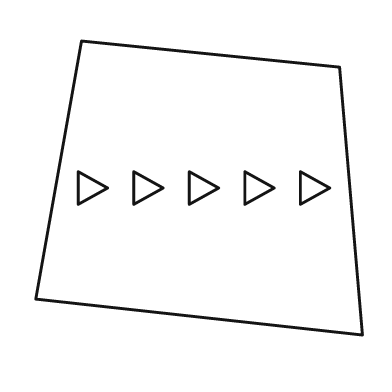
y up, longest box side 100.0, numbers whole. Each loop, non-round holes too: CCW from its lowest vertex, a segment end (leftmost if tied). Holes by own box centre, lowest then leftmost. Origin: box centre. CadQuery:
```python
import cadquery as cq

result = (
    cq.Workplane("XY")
    .moveTo(50.0, -45.0)
    .lineTo(43.0, 37.0)
    .lineTo(-36.0, 45.0)
    .lineTo(-50.0, -34.0)
    .close()
    .moveTo(-37.0, -5.0)
    .lineTo(-28.0, 0.0)
    .lineTo(-37.0, 5.0)
    .close()
    .moveTo(-20.0, -5.0)
    .lineTo(-11.0, 0.0)
    .lineTo(-20.0, 5.0)
    .close()
    .moveTo(-3.0, -5.0)
    .lineTo(6.0, 0.0)
    .lineTo(-3.0, 5.0)
    .close()
    .moveTo(14.0, -5.0)
    .lineTo(23.0, 0.0)
    .lineTo(14.0, 5.0)
    .close()
    .moveTo(31.0, -5.0)
    .lineTo(40.0, 0.0)
    .lineTo(31.0, 5.0)
    .close()
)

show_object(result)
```